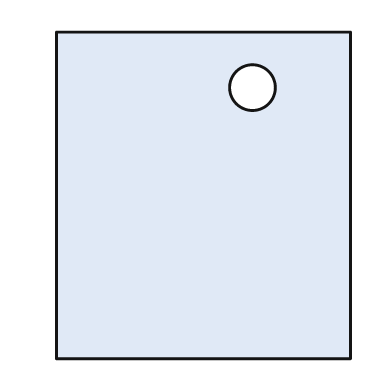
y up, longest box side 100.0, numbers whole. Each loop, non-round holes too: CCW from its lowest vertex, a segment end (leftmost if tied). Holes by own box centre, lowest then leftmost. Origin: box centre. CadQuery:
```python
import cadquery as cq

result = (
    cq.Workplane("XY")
    .moveTo(-45.0, -50.0)
    .lineTo(45.0, -50.0)
    .lineTo(45.0, 50.0)
    .lineTo(-45.0, 50.0)
    .close()
    .moveTo(15.0, 33.0)
    .circle(7.0)
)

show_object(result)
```